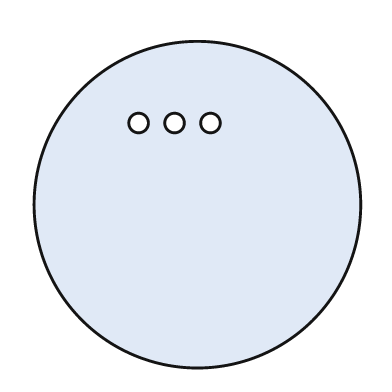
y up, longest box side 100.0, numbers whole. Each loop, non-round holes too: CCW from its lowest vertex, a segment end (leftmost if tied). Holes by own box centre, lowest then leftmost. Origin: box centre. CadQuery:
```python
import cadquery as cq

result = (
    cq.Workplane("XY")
    .moveTo(0.0, 0.0)
    .circle(50.0)
    .moveTo(-18.0, 25.0)
    .circle(3.0)
    .moveTo(-7.0, 25.0)
    .circle(3.0)
    .moveTo(4.0, 25.0)
    .circle(3.0)
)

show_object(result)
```